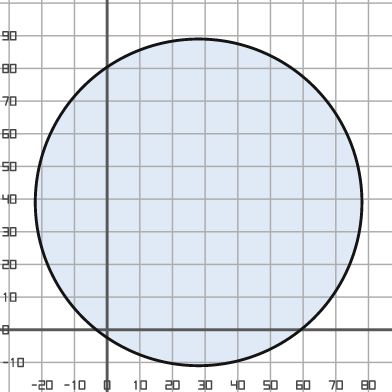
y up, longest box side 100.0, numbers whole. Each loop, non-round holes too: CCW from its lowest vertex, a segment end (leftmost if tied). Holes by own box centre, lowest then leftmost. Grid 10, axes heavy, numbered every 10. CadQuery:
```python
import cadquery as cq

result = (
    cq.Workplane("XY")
    .moveTo(28.0, 39.0)
    .circle(50.0)
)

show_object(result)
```